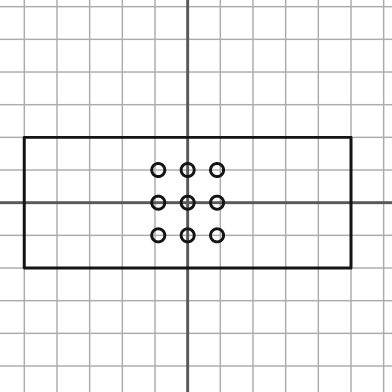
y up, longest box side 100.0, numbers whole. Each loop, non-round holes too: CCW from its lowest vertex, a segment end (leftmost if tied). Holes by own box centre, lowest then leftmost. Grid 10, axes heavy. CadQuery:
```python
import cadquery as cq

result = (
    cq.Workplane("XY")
    .moveTo(-50.0, -20.0)
    .lineTo(50.0, -20.0)
    .lineTo(50.0, 20.0)
    .lineTo(-50.0, 20.0)
    .close()
    .moveTo(-9.0, -10.0)
    .circle(2.0)
    .moveTo(0.0, -10.0)
    .circle(2.0)
    .moveTo(9.0, -10.0)
    .circle(2.0)
    .moveTo(-9.0, 0.0)
    .circle(2.0)
    .moveTo(0.0, 0.0)
    .circle(2.0)
    .moveTo(9.0, 0.0)
    .circle(2.0)
    .moveTo(-9.0, 10.0)
    .circle(2.0)
    .moveTo(0.0, 10.0)
    .circle(2.0)
    .moveTo(9.0, 10.0)
    .circle(2.0)
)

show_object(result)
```